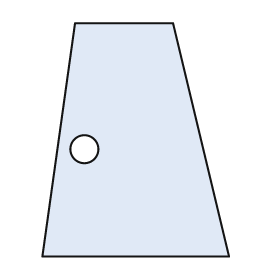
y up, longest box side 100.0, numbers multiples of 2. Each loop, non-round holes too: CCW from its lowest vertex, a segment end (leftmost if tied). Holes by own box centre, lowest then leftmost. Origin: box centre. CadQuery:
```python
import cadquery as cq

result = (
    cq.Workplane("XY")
    .moveTo(-40.0, -50.0)
    .lineTo(40.0, -50.0)
    .lineTo(16.0, 50.0)
    .lineTo(-26.0, 50.0)
    .close()
    .moveTo(-22.0, -4.0)
    .circle(6.0)
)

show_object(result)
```